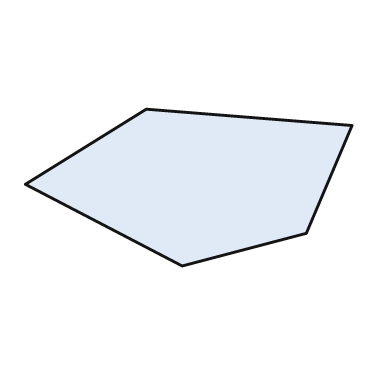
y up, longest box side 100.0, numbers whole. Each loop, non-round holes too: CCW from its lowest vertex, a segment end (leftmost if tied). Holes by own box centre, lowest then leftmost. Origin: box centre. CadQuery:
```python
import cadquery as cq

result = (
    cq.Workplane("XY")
    .moveTo(-2.0, -24.0)
    .lineTo(36.0, -14.0)
    .lineTo(50.0, 19.0)
    .lineTo(-13.0, 24.0)
    .lineTo(-50.0, 1.0)
    .close()
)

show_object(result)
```